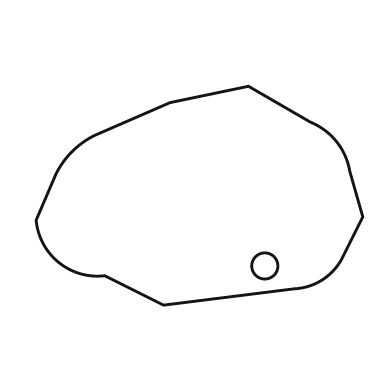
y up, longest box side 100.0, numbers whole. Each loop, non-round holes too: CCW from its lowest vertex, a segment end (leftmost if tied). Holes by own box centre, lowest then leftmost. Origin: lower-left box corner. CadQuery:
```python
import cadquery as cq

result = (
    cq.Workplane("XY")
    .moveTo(39.0, 0.0)
    .lineTo(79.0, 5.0)
    .threePointArc((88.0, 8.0), (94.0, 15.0))
    .lineTo(100.0, 27.0)
    .lineTo(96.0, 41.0)
    .threePointArc((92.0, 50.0), (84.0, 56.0))
    .lineTo(65.0, 67.0)
    .lineTo(41.0, 62.0)
    .lineTo(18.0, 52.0)
    .threePointArc((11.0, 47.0), (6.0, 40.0))
    .lineTo(0.0, 26.0)
    .threePointArc((7.0, 13.0), (21.0, 9.0))
    .close()
    .moveTo(70.0, 12.0)
    .circle(4.0)
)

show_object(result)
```